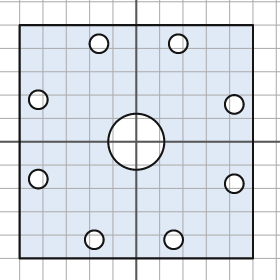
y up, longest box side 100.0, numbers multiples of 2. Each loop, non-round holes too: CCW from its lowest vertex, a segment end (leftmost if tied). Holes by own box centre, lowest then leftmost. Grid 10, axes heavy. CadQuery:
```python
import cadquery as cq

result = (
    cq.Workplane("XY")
    .moveTo(-50.0, -50.0)
    .lineTo(50.0, -50.0)
    .lineTo(50.0, 50.0)
    .lineTo(-50.0, 50.0)
    .close()
    .moveTo(-18.0, -42.0)
    .circle(4.0)
    .moveTo(16.0, -42.0)
    .circle(4.0)
    .moveTo(42.0, -18.0)
    .circle(4.0)
    .moveTo(-42.0, -16.0)
    .circle(4.0)
    .moveTo(0.0, 0.0)
    .circle(12.0)
    .moveTo(42.0, 16.0)
    .circle(4.0)
    .moveTo(-42.0, 18.0)
    .circle(4.0)
    .moveTo(-16.0, 42.0)
    .circle(4.0)
    .moveTo(18.0, 42.0)
    .circle(4.0)
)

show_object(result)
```